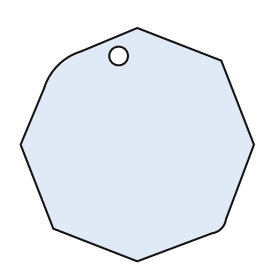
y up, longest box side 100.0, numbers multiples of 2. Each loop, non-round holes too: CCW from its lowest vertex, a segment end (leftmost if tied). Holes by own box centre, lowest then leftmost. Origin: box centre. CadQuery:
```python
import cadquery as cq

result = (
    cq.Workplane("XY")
    .moveTo(0.0, -50.0)
    .lineTo(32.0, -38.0)
    .threePointArc((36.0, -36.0), (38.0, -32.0))
    .lineTo(50.0, 0.0)
    .lineTo(36.0, 36.0)
    .lineTo(0.0, 50.0)
    .lineTo(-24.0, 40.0)
    .threePointArc((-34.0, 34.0), (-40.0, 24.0))
    .lineTo(-50.0, 0.0)
    .lineTo(-36.0, -36.0)
    .close()
    .moveTo(-8.0, 38.0)
    .circle(4.0)
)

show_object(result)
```